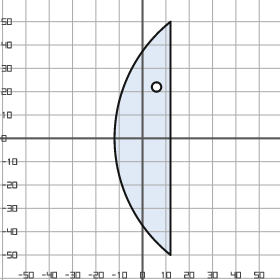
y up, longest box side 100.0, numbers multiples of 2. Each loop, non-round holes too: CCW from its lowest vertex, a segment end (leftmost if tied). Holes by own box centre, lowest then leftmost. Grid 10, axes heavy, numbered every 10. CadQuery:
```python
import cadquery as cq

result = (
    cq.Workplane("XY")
    .moveTo(12.0, -50.0)
    .lineTo(12.0, 50.0)
    .threePointArc((-12.0, 0.0), (12.0, -50.0))
    .close()
    .moveTo(6.0, 22.0)
    .circle(2.0)
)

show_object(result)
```